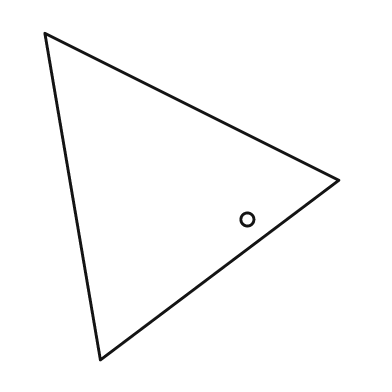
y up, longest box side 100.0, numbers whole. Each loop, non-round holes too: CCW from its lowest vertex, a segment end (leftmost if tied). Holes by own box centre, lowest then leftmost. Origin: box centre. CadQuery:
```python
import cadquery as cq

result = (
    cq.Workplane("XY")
    .moveTo(-28.0, -50.0)
    .lineTo(45.0, 5.0)
    .lineTo(-45.0, 50.0)
    .close()
    .moveTo(17.0, -7.0)
    .circle(2.0)
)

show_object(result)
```